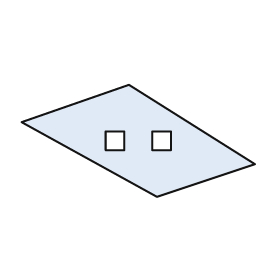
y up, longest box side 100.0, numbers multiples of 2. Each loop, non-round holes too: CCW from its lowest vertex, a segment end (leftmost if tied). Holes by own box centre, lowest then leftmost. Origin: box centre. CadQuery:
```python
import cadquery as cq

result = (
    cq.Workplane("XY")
    .moveTo(8.0, -24.0)
    .lineTo(50.0, -10.0)
    .lineTo(-4.0, 24.0)
    .lineTo(-50.0, 8.0)
    .close()
    .moveTo(-14.0, -4.0)
    .lineTo(-6.0, -4.0)
    .lineTo(-6.0, 4.0)
    .lineTo(-14.0, 4.0)
    .close()
    .moveTo(6.0, -4.0)
    .lineTo(14.0, -4.0)
    .lineTo(14.0, 4.0)
    .lineTo(6.0, 4.0)
    .close()
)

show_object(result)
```